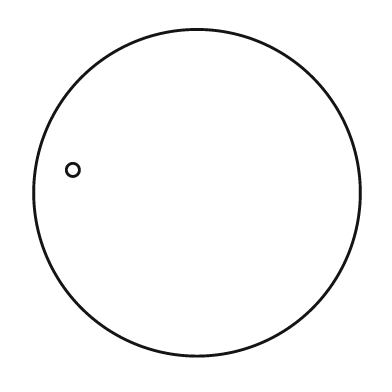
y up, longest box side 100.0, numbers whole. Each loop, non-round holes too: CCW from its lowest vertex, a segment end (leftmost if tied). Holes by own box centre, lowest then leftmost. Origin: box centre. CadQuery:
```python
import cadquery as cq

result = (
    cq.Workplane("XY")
    .moveTo(0.0, 0.0)
    .circle(50.0)
    .moveTo(-38.0, 7.0)
    .circle(2.0)
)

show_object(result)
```